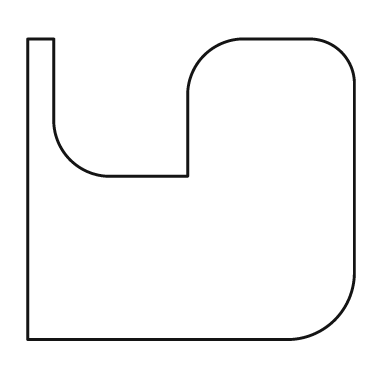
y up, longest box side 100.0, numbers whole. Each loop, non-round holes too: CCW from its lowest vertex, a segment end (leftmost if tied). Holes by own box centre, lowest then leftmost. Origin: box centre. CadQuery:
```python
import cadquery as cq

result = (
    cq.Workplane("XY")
    .moveTo(-50.0, -46.0)
    .lineTo(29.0, -46.0)
    .threePointArc((44.0, -40.0), (50.0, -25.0))
    .lineTo(50.0, 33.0)
    .threePointArc((46.0, 42.0), (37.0, 46.0))
    .lineTo(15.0, 46.0)
    .threePointArc((4.0, 41.0), (-1.0, 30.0))
    .lineTo(-1.0, 4.0)
    .lineTo(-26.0, 4.0)
    .threePointArc((-37.0, 9.0), (-42.0, 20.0))
    .lineTo(-42.0, 46.0)
    .lineTo(-50.0, 46.0)
    .close()
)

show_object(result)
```